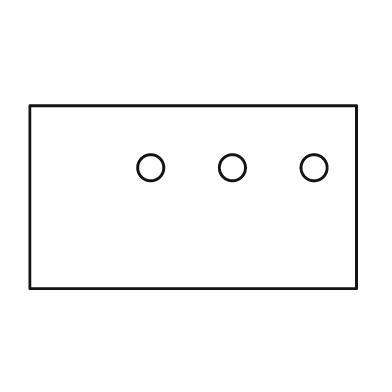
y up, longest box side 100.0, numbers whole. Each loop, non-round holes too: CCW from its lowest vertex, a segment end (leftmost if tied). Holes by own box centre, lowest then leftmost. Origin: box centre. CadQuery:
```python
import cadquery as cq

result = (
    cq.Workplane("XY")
    .moveTo(-50.0, -28.0)
    .lineTo(50.0, -28.0)
    .lineTo(50.0, 28.0)
    .lineTo(-50.0, 28.0)
    .close()
    .moveTo(-13.0, 9.0)
    .circle(4.0)
    .moveTo(12.0, 9.0)
    .circle(4.0)
    .moveTo(37.0, 9.0)
    .circle(4.0)
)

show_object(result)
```